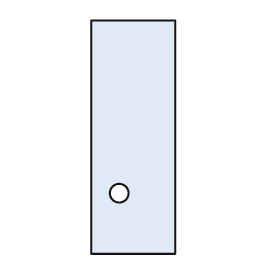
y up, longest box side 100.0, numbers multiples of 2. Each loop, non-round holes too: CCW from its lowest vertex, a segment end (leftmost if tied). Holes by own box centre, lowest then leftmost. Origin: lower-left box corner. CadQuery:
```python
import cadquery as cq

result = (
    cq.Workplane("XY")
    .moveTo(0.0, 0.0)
    .lineTo(36.0, 0.0)
    .lineTo(36.0, 100.0)
    .lineTo(0.0, 100.0)
    .close()
    .moveTo(12.0, 26.0)
    .circle(4.0)
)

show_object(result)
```